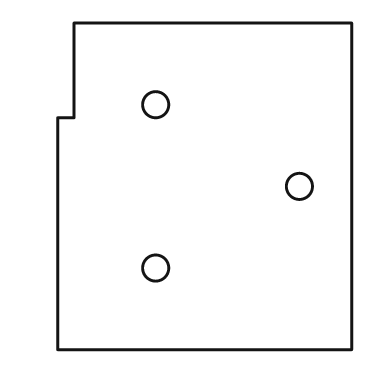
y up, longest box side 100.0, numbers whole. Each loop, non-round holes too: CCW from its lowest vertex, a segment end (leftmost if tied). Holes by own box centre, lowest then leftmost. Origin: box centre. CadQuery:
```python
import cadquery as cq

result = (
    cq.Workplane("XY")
    .moveTo(-45.0, -50.0)
    .lineTo(45.0, -50.0)
    .lineTo(45.0, 50.0)
    .lineTo(-40.0, 50.0)
    .lineTo(-40.0, 21.0)
    .lineTo(-45.0, 21.0)
    .close()
    .moveTo(-15.0, -25.0)
    .circle(4.0)
    .moveTo(29.0, 0.0)
    .circle(4.0)
    .moveTo(-15.0, 25.0)
    .circle(4.0)
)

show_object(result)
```